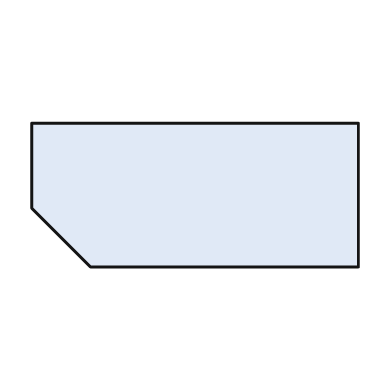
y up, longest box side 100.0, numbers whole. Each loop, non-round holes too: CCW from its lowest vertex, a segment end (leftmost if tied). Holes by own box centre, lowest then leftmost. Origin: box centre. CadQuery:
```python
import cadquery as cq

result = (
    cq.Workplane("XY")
    .moveTo(-32.0, -22.0)
    .lineTo(50.0, -22.0)
    .lineTo(50.0, 22.0)
    .lineTo(-50.0, 22.0)
    .lineTo(-50.0, -4.0)
    .close()
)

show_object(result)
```